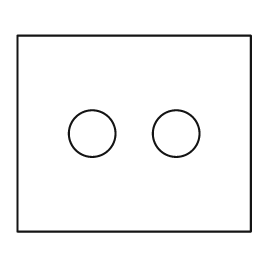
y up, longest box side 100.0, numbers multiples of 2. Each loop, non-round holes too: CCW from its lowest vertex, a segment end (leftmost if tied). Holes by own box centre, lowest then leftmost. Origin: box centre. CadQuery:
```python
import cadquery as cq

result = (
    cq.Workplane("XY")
    .moveTo(-50.0, -42.0)
    .lineTo(50.0, -42.0)
    .lineTo(50.0, 42.0)
    .lineTo(-50.0, 42.0)
    .close()
    .moveTo(-18.0, 0.0)
    .circle(10.0)
    .moveTo(18.0, 0.0)
    .circle(10.0)
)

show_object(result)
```